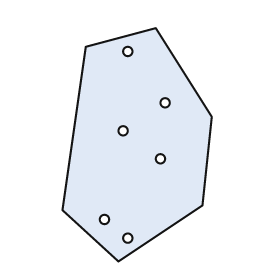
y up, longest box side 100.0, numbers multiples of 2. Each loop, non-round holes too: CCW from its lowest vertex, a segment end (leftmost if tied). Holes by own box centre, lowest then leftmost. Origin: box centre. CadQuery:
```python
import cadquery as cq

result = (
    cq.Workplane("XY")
    .moveTo(-8.0, -50.0)
    .lineTo(28.0, -26.0)
    .lineTo(32.0, 12.0)
    .lineTo(8.0, 50.0)
    .lineTo(-22.0, 42.0)
    .lineTo(-32.0, -28.0)
    .close()
    .moveTo(-4.0, -40.0)
    .circle(2.0)
    .moveTo(-14.0, -32.0)
    .circle(2.0)
    .moveTo(10.0, -6.0)
    .circle(2.0)
    .moveTo(-6.0, 6.0)
    .circle(2.0)
    .moveTo(12.0, 18.0)
    .circle(2.0)
    .moveTo(-4.0, 40.0)
    .circle(2.0)
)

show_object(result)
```